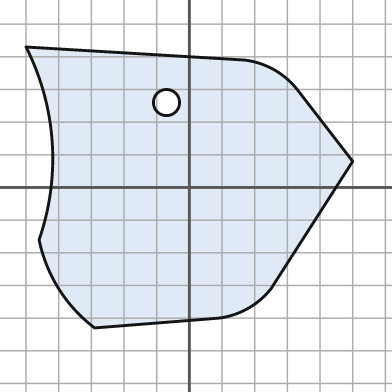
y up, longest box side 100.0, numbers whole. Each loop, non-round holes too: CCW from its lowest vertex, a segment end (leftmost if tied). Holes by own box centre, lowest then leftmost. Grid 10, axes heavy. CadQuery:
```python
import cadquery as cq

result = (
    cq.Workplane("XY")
    .moveTo(-29.0, -43.0)
    .lineTo(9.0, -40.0)
    .threePointArc((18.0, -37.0), (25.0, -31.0))
    .lineTo(50.0, 8.0)
    .lineTo(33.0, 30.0)
    .threePointArc((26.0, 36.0), (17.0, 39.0))
    .lineTo(-50.0, 43.0)
    .threePointArc((-42.0, 14.0), (-46.0, -16.0))
    .threePointArc((-40.0, -31.0), (-29.0, -43.0))
    .close()
    .moveTo(-7.0, 26.0)
    .circle(4.0)
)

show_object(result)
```